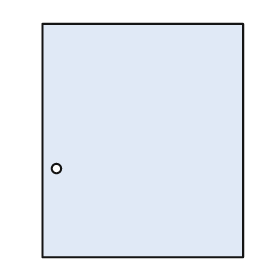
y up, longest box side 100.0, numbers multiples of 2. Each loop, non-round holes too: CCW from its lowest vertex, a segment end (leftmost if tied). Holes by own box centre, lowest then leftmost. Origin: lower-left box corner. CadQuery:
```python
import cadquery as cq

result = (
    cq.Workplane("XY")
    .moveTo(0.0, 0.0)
    .lineTo(86.0, 0.0)
    .lineTo(86.0, 100.0)
    .lineTo(0.0, 100.0)
    .close()
    .moveTo(6.0, 38.0)
    .circle(2.0)
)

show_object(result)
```